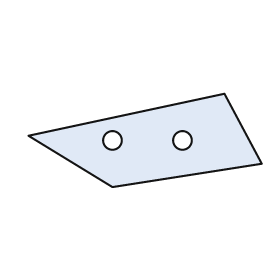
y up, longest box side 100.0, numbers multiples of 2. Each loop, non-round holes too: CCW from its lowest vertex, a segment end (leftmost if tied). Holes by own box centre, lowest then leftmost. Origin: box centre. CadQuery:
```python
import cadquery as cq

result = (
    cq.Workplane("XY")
    .moveTo(-14.0, -20.0)
    .lineTo(50.0, -10.0)
    .lineTo(34.0, 20.0)
    .lineTo(-50.0, 2.0)
    .close()
    .moveTo(-14.0, 0.0)
    .circle(4.0)
    .moveTo(16.0, 0.0)
    .circle(4.0)
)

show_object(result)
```